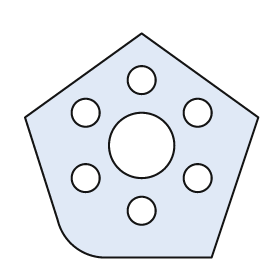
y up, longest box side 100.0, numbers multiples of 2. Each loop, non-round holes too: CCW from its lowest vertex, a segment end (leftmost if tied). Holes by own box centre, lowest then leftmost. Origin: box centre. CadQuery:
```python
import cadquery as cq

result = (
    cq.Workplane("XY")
    .moveTo(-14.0, -48.0)
    .lineTo(30.0, -48.0)
    .lineTo(50.0, 12.0)
    .lineTo(0.0, 48.0)
    .lineTo(-50.0, 12.0)
    .lineTo(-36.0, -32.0)
    .threePointArc((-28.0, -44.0), (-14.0, -48.0))
    .close()
    .moveTo(0.0, -28.0)
    .circle(6.0)
    .moveTo(-24.0, -14.0)
    .circle(6.0)
    .moveTo(24.0, -14.0)
    .circle(6.0)
    .moveTo(0.0, 0.0)
    .circle(14.0)
    .moveTo(-24.0, 14.0)
    .circle(6.0)
    .moveTo(24.0, 14.0)
    .circle(6.0)
    .moveTo(0.0, 28.0)
    .circle(6.0)
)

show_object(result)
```